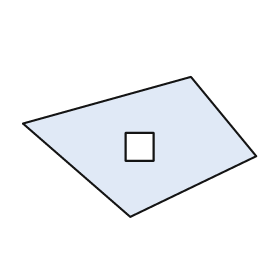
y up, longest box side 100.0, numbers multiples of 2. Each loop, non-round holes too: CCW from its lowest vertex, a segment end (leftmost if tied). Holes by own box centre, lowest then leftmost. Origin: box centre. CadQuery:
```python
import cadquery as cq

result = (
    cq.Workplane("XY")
    .moveTo(-4.0, -30.0)
    .lineTo(50.0, -4.0)
    .lineTo(22.0, 30.0)
    .lineTo(-50.0, 10.0)
    .close()
    .moveTo(-6.0, -6.0)
    .lineTo(6.0, -6.0)
    .lineTo(6.0, 6.0)
    .lineTo(-6.0, 6.0)
    .close()
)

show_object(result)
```